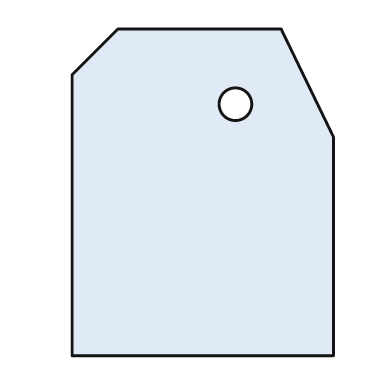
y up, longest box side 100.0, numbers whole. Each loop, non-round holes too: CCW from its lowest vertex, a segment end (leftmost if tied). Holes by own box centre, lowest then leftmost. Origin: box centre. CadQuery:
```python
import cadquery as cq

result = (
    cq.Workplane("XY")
    .moveTo(-40.0, -50.0)
    .lineTo(40.0, -50.0)
    .lineTo(40.0, 17.0)
    .lineTo(24.0, 50.0)
    .lineTo(-26.0, 50.0)
    .lineTo(-40.0, 36.0)
    .close()
    .moveTo(10.0, 27.0)
    .circle(5.0)
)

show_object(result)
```